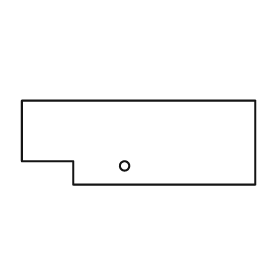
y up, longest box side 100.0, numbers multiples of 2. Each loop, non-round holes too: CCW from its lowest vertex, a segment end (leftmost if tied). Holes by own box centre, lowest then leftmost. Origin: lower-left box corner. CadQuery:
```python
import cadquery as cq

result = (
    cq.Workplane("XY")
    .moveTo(22.0, 0.0)
    .lineTo(100.0, 0.0)
    .lineTo(100.0, 36.0)
    .lineTo(0.0, 36.0)
    .lineTo(0.0, 10.0)
    .lineTo(22.0, 10.0)
    .close()
    .moveTo(44.0, 8.0)
    .circle(2.0)
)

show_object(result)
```